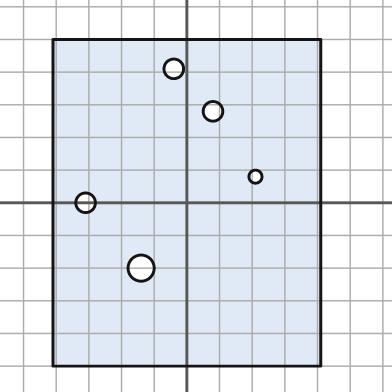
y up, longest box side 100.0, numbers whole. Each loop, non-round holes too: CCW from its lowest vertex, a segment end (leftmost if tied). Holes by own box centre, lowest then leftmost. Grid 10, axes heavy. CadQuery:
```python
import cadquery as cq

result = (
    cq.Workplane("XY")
    .moveTo(-41.0, -50.0)
    .lineTo(41.0, -50.0)
    .lineTo(41.0, 50.0)
    .lineTo(-41.0, 50.0)
    .close()
    .moveTo(-14.0, -20.0)
    .circle(4.0)
    .moveTo(-31.0, 0.0)
    .circle(3.0)
    .moveTo(21.0, 8.0)
    .circle(2.0)
    .moveTo(8.0, 28.0)
    .circle(3.0)
    .moveTo(-4.0, 41.0)
    .circle(3.0)
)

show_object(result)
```